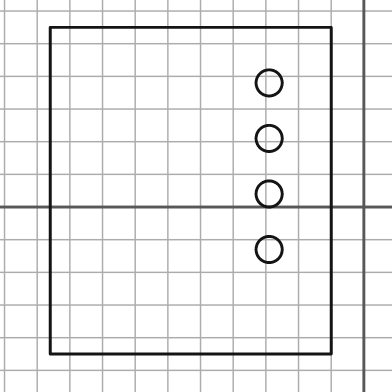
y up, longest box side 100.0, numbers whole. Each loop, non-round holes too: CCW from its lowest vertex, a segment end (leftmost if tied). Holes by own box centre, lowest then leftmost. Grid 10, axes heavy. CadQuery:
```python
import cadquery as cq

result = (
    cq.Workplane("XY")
    .moveTo(-96.0, -45.0)
    .lineTo(-10.0, -45.0)
    .lineTo(-10.0, 55.0)
    .lineTo(-96.0, 55.0)
    .close()
    .moveTo(-29.0, -13.0)
    .circle(4.0)
    .moveTo(-29.0, 4.0)
    .circle(4.0)
    .moveTo(-29.0, 21.0)
    .circle(4.0)
    .moveTo(-29.0, 38.0)
    .circle(4.0)
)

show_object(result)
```